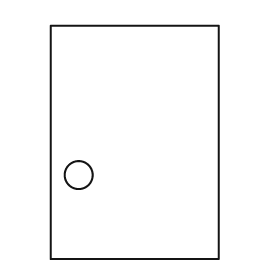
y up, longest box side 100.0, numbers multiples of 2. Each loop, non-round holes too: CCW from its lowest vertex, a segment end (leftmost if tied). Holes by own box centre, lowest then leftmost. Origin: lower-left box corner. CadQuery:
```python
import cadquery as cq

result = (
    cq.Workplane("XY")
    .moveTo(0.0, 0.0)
    .lineTo(72.0, 0.0)
    .lineTo(72.0, 100.0)
    .lineTo(0.0, 100.0)
    .close()
    .moveTo(12.0, 36.0)
    .circle(6.0)
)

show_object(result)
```